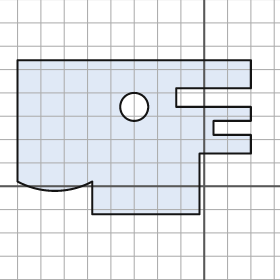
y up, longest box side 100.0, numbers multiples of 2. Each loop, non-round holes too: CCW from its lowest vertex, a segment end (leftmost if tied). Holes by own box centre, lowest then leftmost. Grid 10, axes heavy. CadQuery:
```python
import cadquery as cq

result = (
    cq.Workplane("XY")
    .moveTo(-48.0, -12.0)
    .lineTo(-2.0, -12.0)
    .lineTo(-2.0, 14.0)
    .lineTo(20.0, 14.0)
    .lineTo(20.0, 22.0)
    .lineTo(4.0, 22.0)
    .lineTo(4.0, 28.0)
    .lineTo(20.0, 28.0)
    .lineTo(20.0, 34.0)
    .lineTo(-12.0, 34.0)
    .lineTo(-12.0, 42.0)
    .lineTo(20.0, 42.0)
    .lineTo(20.0, 54.0)
    .lineTo(-80.0, 54.0)
    .lineTo(-80.0, 2.0)
    .threePointArc((-64.0, -2.0), (-48.0, 2.0))
    .close()
    .moveTo(-30.0, 34.0)
    .circle(6.0)
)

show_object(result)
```